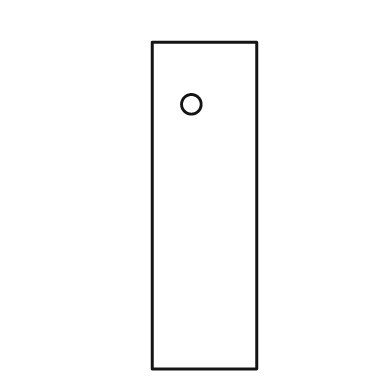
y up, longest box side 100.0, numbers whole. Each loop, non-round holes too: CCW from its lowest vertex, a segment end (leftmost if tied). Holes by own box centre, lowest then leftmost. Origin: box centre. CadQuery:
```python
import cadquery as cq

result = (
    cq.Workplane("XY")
    .moveTo(-16.0, -50.0)
    .lineTo(16.0, -50.0)
    .lineTo(16.0, 50.0)
    .lineTo(-16.0, 50.0)
    .close()
    .moveTo(-4.0, 31.0)
    .circle(3.0)
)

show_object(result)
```